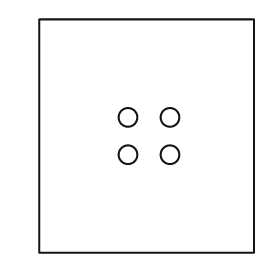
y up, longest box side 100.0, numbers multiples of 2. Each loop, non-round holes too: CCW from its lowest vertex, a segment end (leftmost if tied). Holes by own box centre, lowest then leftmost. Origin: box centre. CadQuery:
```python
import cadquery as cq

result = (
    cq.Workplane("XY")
    .moveTo(-46.0, -50.0)
    .lineTo(46.0, -50.0)
    .lineTo(46.0, 50.0)
    .lineTo(-46.0, 50.0)
    .close()
    .moveTo(-8.0, -8.0)
    .circle(4.0)
    .moveTo(10.0, -8.0)
    .circle(4.0)
    .moveTo(-8.0, 8.0)
    .circle(4.0)
    .moveTo(10.0, 8.0)
    .circle(4.0)
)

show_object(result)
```